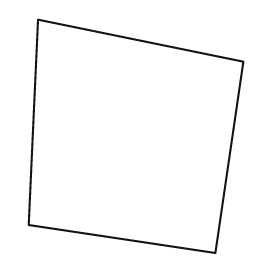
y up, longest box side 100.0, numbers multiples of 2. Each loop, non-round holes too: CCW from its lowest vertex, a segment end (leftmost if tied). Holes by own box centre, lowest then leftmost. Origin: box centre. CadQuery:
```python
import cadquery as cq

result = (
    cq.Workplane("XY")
    .moveTo(34.0, -50.0)
    .lineTo(46.0, 32.0)
    .lineTo(-42.0, 50.0)
    .lineTo(-46.0, -38.0)
    .close()
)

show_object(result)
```